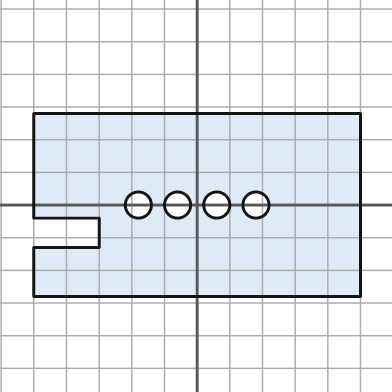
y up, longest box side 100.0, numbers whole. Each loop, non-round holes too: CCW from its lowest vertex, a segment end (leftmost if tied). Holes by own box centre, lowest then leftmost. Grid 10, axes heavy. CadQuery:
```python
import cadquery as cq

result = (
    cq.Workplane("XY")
    .moveTo(-50.0, -28.0)
    .lineTo(50.0, -28.0)
    .lineTo(50.0, 28.0)
    .lineTo(-50.0, 28.0)
    .lineTo(-50.0, -4.0)
    .lineTo(-30.0, -4.0)
    .lineTo(-30.0, -13.0)
    .lineTo(-50.0, -13.0)
    .close()
    .moveTo(-18.0, 0.0)
    .circle(4.0)
    .moveTo(-6.0, 0.0)
    .circle(4.0)
    .moveTo(6.0, 0.0)
    .circle(4.0)
    .moveTo(18.0, 0.0)
    .circle(4.0)
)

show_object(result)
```